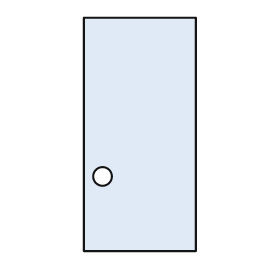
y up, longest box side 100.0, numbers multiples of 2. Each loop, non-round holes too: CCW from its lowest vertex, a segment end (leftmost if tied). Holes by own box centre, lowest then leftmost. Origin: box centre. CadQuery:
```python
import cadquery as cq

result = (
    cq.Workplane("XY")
    .moveTo(-24.0, -50.0)
    .lineTo(24.0, -50.0)
    .lineTo(24.0, 50.0)
    .lineTo(-24.0, 50.0)
    .close()
    .moveTo(-16.0, -18.0)
    .circle(4.0)
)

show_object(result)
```